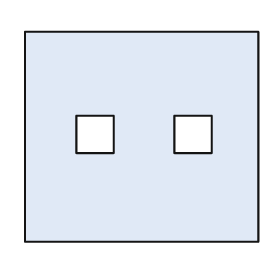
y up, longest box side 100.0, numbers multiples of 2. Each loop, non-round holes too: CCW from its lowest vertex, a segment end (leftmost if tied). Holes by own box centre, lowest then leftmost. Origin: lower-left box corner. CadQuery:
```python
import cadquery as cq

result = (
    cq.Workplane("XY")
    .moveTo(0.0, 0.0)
    .lineTo(100.0, 0.0)
    .lineTo(100.0, 90.0)
    .lineTo(0.0, 90.0)
    .close()
    .moveTo(22.0, 38.0)
    .lineTo(38.0, 38.0)
    .lineTo(38.0, 54.0)
    .lineTo(22.0, 54.0)
    .close()
    .moveTo(64.0, 38.0)
    .lineTo(80.0, 38.0)
    .lineTo(80.0, 54.0)
    .lineTo(64.0, 54.0)
    .close()
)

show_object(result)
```